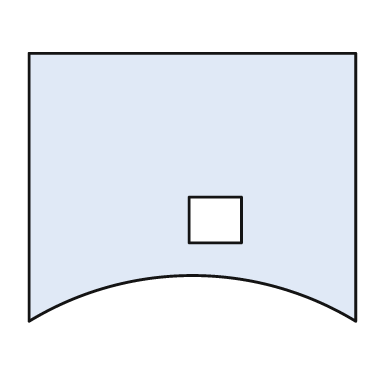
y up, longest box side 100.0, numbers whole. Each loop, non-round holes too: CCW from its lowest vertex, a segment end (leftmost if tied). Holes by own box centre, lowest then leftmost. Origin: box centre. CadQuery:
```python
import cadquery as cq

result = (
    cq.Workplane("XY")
    .moveTo(-50.0, -41.0)
    .threePointArc((0.0, -27.0), (50.0, -41.0))
    .lineTo(50.0, 41.0)
    .lineTo(-50.0, 41.0)
    .close()
    .moveTo(-1.0, -17.0)
    .lineTo(15.0, -17.0)
    .lineTo(15.0, -3.0)
    .lineTo(-1.0, -3.0)
    .close()
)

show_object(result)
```